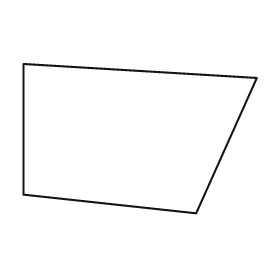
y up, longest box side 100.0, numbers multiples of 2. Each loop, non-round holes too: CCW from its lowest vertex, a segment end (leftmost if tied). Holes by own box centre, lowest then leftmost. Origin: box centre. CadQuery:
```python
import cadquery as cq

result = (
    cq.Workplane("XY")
    .moveTo(24.0, -32.0)
    .lineTo(50.0, 26.0)
    .lineTo(-50.0, 32.0)
    .lineTo(-50.0, -24.0)
    .close()
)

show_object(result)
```